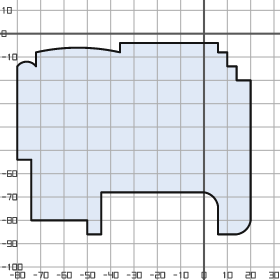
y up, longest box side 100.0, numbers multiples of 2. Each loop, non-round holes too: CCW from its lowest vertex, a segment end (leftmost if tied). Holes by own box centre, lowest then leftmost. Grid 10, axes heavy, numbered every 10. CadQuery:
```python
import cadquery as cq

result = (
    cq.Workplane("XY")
    .moveTo(-50.0, -86.0)
    .lineTo(-44.0, -86.0)
    .lineTo(-44.0, -68.0)
    .lineTo(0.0, -68.0)
    .threePointArc((4.0, -70.0), (6.0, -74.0))
    .lineTo(6.0, -86.0)
    .lineTo(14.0, -86.0)
    .threePointArc((18.0, -84.0), (20.0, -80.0))
    .lineTo(20.0, -20.0)
    .lineTo(14.0, -20.0)
    .lineTo(14.0, -14.0)
    .lineTo(10.0, -14.0)
    .lineTo(10.0, -8.0)
    .lineTo(6.0, -8.0)
    .lineTo(6.0, -4.0)
    .lineTo(-36.0, -4.0)
    .lineTo(-36.0, -8.0)
    .threePointArc((-54.0, -6.0), (-72.0, -8.0))
    .lineTo(-72.0, -14.0)
    .threePointArc((-76.0, -12.0), (-80.0, -14.0))
    .lineTo(-80.0, -54.0)
    .lineTo(-74.0, -54.0)
    .lineTo(-74.0, -80.0)
    .lineTo(-50.0, -80.0)
    .close()
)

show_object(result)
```